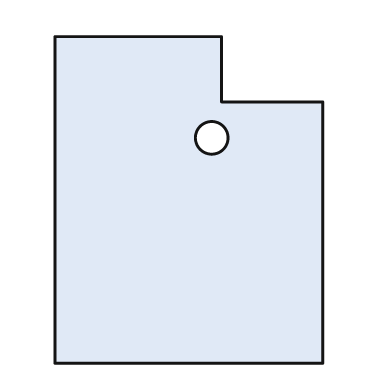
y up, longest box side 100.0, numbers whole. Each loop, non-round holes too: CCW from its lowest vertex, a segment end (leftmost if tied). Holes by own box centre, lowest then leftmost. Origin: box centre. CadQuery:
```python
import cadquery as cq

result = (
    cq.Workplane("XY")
    .moveTo(-41.0, -50.0)
    .lineTo(41.0, -50.0)
    .lineTo(41.0, 30.0)
    .lineTo(10.0, 30.0)
    .lineTo(10.0, 50.0)
    .lineTo(-41.0, 50.0)
    .close()
    .moveTo(7.0, 19.0)
    .circle(5.0)
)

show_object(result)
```